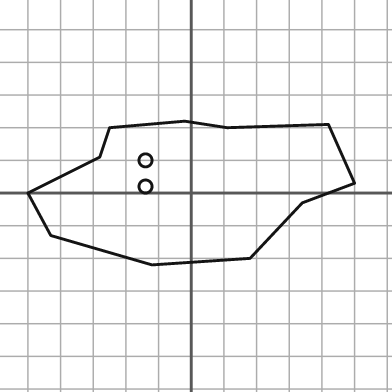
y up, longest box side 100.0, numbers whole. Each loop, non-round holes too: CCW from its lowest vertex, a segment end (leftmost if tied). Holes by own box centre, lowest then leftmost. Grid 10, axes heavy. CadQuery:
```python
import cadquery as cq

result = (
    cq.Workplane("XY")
    .moveTo(-12.0, -22.0)
    .lineTo(18.0, -20.0)
    .lineTo(34.0, -3.0)
    .lineTo(50.0, 3.0)
    .lineTo(42.0, 21.0)
    .lineTo(11.0, 20.0)
    .lineTo(-2.0, 22.0)
    .lineTo(-25.0, 20.0)
    .lineTo(-28.0, 11.0)
    .lineTo(-50.0, 0.0)
    .lineTo(-43.0, -13.0)
    .close()
    .moveTo(-14.0, 2.0)
    .circle(2.0)
    .moveTo(-14.0, 10.0)
    .circle(2.0)
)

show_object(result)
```